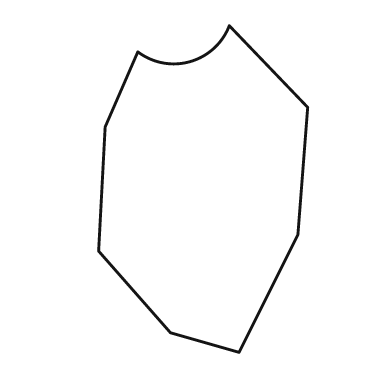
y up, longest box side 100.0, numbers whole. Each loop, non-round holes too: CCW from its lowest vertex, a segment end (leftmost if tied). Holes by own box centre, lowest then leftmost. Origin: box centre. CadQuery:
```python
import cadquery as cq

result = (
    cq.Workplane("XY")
    .moveTo(11.0, -50.0)
    .lineTo(29.0, -14.0)
    .lineTo(32.0, 25.0)
    .lineTo(8.0, 50.0)
    .threePointArc((-4.0, 39.0), (-20.0, 42.0))
    .lineTo(-30.0, 19.0)
    .lineTo(-32.0, -19.0)
    .lineTo(-10.0, -44.0)
    .close()
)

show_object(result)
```